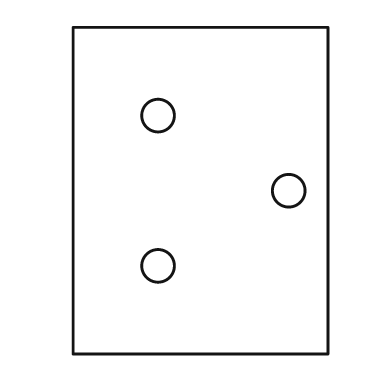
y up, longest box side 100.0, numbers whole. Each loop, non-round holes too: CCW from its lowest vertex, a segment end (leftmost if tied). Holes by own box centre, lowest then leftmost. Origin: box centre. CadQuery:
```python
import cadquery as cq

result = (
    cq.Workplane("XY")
    .moveTo(-39.0, -50.0)
    .lineTo(39.0, -50.0)
    .lineTo(39.0, 50.0)
    .lineTo(-39.0, 50.0)
    .close()
    .moveTo(-13.0, -23.0)
    .circle(5.0)
    .moveTo(27.0, 0.0)
    .circle(5.0)
    .moveTo(-13.0, 23.0)
    .circle(5.0)
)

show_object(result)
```